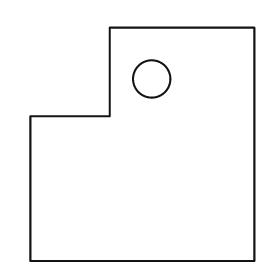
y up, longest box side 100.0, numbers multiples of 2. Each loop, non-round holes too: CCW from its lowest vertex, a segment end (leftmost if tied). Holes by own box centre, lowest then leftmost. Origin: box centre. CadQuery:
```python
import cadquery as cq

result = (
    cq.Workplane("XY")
    .moveTo(-48.0, -50.0)
    .lineTo(48.0, -50.0)
    .lineTo(48.0, 50.0)
    .lineTo(-14.0, 50.0)
    .lineTo(-14.0, 12.0)
    .lineTo(-48.0, 12.0)
    .close()
    .moveTo(4.0, 28.0)
    .circle(8.0)
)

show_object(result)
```